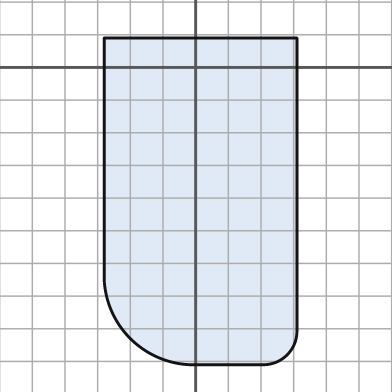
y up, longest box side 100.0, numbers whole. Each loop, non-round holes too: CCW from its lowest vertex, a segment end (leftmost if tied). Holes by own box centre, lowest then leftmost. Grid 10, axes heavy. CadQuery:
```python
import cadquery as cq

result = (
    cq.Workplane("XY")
    .moveTo(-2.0, -91.0)
    .lineTo(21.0, -91.0)
    .threePointArc((28.0, -88.0), (31.0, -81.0))
    .lineTo(31.0, 9.0)
    .lineTo(-28.0, 9.0)
    .lineTo(-28.0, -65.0)
    .threePointArc((-20.0, -83.0), (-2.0, -91.0))
    .close()
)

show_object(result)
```